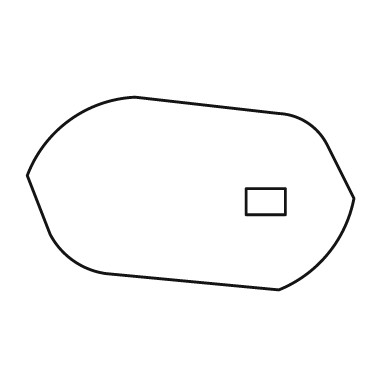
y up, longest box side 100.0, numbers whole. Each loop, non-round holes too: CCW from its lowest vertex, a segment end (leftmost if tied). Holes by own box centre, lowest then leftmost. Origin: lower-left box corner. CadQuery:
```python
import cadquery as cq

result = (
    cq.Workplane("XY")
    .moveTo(77.0, 0.0)
    .threePointArc((92.0, 11.0), (100.0, 28.0))
    .lineTo(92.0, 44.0)
    .threePointArc((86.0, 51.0), (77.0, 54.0))
    .lineTo(33.0, 59.0)
    .threePointArc((13.0, 52.0), (0.0, 35.0))
    .lineTo(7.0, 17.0)
    .threePointArc((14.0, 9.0), (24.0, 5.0))
    .close()
    .moveTo(67.0, 23.0)
    .lineTo(79.0, 23.0)
    .lineTo(79.0, 31.0)
    .lineTo(67.0, 31.0)
    .close()
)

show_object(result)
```